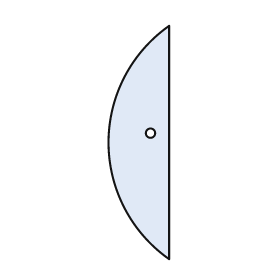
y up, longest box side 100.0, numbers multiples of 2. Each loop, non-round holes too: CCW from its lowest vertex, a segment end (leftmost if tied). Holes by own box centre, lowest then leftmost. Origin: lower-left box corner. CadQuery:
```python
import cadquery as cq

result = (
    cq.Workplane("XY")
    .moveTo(26.0, 0.0)
    .lineTo(26.0, 100.0)
    .threePointArc((0.0, 50.0), (26.0, 0.0))
    .close()
    .moveTo(18.0, 54.0)
    .circle(2.0)
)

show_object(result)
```